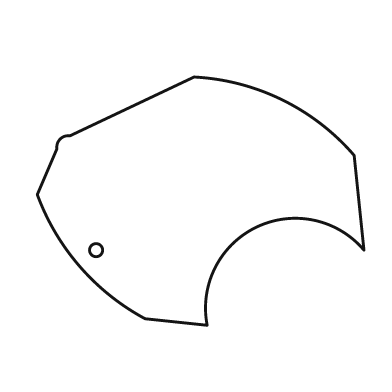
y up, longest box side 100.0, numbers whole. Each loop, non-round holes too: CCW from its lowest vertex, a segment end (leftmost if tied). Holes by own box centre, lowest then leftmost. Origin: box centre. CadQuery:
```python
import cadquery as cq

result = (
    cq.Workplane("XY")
    .moveTo(2.0, -38.0)
    .threePointArc((17.0, -8.0), (50.0, -15.0))
    .lineTo(47.0, 14.0)
    .threePointArc((25.0, 31.0), (-2.0, 38.0))
    .lineTo(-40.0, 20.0)
    .threePointArc((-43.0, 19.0), (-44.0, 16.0))
    .lineTo(-50.0, 2.0)
    .threePointArc((-37.0, -20.0), (-17.0, -36.0))
    .close()
    .moveTo(-32.0, -15.0)
    .circle(2.0)
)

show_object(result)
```